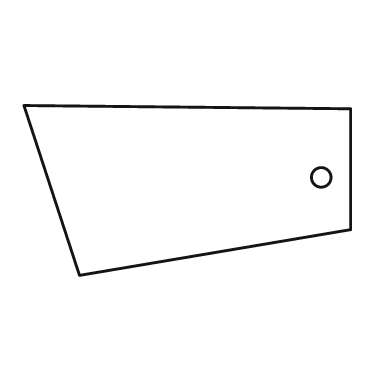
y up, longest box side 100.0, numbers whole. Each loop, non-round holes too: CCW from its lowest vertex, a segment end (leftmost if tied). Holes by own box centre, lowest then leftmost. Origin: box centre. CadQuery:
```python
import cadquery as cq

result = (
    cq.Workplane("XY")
    .moveTo(-33.0, -26.0)
    .lineTo(50.0, -12.0)
    .lineTo(50.0, 25.0)
    .lineTo(-50.0, 26.0)
    .close()
    .moveTo(41.0, 4.0)
    .circle(3.0)
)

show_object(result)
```